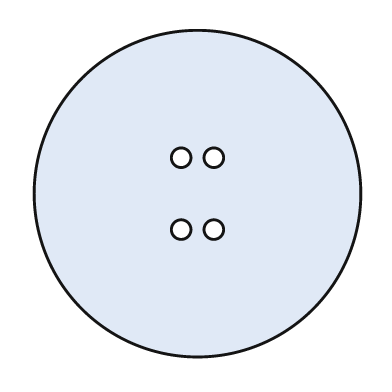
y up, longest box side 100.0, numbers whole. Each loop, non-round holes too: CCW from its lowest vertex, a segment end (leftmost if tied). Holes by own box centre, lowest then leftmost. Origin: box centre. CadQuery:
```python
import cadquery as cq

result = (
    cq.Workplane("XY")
    .moveTo(0.0, 0.0)
    .circle(50.0)
    .moveTo(-5.0, -11.0)
    .circle(3.0)
    .moveTo(5.0, -11.0)
    .circle(3.0)
    .moveTo(-5.0, 11.0)
    .circle(3.0)
    .moveTo(5.0, 11.0)
    .circle(3.0)
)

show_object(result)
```